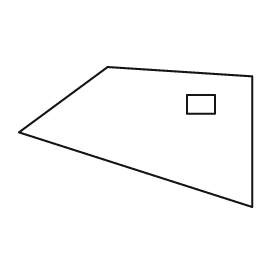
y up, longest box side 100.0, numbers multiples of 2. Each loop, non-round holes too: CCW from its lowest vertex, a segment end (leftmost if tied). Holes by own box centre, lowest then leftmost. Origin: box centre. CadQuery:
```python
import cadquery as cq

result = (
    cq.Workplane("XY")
    .moveTo(50.0, -30.0)
    .lineTo(50.0, 26.0)
    .lineTo(-12.0, 30.0)
    .lineTo(-50.0, 2.0)
    .close()
    .moveTo(22.0, 10.0)
    .lineTo(34.0, 10.0)
    .lineTo(34.0, 18.0)
    .lineTo(22.0, 18.0)
    .close()
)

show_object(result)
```